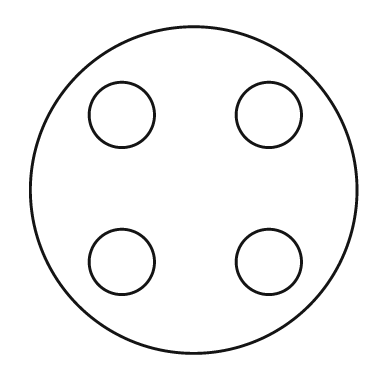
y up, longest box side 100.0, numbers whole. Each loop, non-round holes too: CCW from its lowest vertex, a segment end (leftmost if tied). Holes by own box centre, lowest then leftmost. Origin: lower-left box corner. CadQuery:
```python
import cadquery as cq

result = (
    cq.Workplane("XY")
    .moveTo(50.0, 50.0)
    .circle(50.0)
    .moveTo(28.0, 28.0)
    .circle(10.0)
    .moveTo(73.0, 28.0)
    .circle(10.0)
    .moveTo(28.0, 73.0)
    .circle(10.0)
    .moveTo(73.0, 73.0)
    .circle(10.0)
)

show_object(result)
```